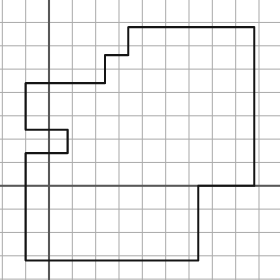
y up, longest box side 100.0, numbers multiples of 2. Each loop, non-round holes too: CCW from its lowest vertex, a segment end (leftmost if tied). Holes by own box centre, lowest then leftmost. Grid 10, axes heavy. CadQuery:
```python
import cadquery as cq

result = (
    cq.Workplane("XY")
    .moveTo(-10.0, -32.0)
    .lineTo(64.0, -32.0)
    .lineTo(64.0, 0.0)
    .lineTo(88.0, 0.0)
    .lineTo(88.0, 68.0)
    .lineTo(34.0, 68.0)
    .lineTo(34.0, 56.0)
    .lineTo(24.0, 56.0)
    .lineTo(24.0, 44.0)
    .lineTo(-10.0, 44.0)
    .lineTo(-10.0, 24.0)
    .lineTo(8.0, 24.0)
    .lineTo(8.0, 14.0)
    .lineTo(-10.0, 14.0)
    .close()
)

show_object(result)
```